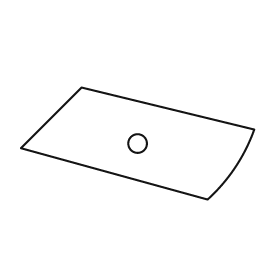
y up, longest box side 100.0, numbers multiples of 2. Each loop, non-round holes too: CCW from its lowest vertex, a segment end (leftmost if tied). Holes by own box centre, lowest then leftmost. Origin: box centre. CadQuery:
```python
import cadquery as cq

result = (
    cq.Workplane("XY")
    .moveTo(30.0, -24.0)
    .threePointArc((42.0, -10.0), (50.0, 6.0))
    .lineTo(-24.0, 24.0)
    .lineTo(-50.0, -2.0)
    .close()
    .moveTo(0.0, 0.0)
    .circle(4.0)
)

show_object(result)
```